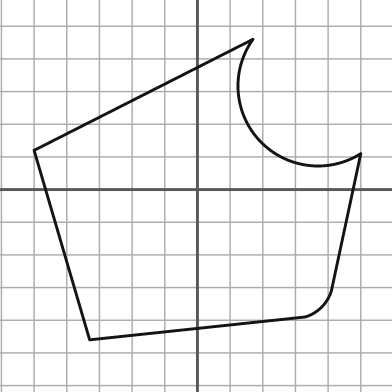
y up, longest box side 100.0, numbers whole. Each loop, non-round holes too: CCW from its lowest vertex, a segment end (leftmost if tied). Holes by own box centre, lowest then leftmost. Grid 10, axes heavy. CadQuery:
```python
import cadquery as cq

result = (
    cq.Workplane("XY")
    .moveTo(-33.0, -46.0)
    .lineTo(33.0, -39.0)
    .threePointArc((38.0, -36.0), (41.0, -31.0))
    .lineTo(50.0, 11.0)
    .threePointArc((19.0, 15.0), (17.0, 46.0))
    .lineTo(-50.0, 12.0)
    .close()
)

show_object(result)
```